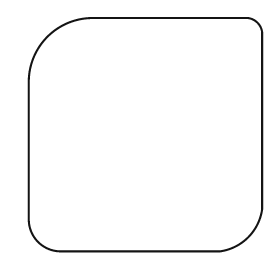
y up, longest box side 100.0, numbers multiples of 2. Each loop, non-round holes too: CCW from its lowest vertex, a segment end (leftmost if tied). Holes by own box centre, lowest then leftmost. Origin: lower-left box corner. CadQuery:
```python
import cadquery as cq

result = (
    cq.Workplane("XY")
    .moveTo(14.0, 0.0)
    .lineTo(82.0, 0.0)
    .threePointArc((94.0, 6.0), (100.0, 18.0))
    .lineTo(100.0, 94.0)
    .threePointArc((98.0, 98.0), (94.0, 100.0))
    .lineTo(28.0, 100.0)
    .threePointArc((8.0, 92.0), (0.0, 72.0))
    .lineTo(0.0, 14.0)
    .threePointArc((4.0, 4.0), (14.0, 0.0))
    .close()
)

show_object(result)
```